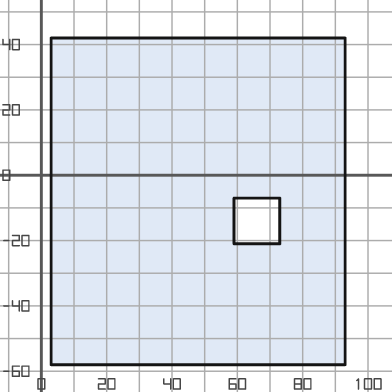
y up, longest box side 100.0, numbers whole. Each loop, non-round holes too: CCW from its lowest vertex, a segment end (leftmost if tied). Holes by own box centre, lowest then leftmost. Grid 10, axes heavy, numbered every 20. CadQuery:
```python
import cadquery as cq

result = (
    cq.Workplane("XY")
    .moveTo(3.0, -58.0)
    .lineTo(93.0, -58.0)
    .lineTo(93.0, 42.0)
    .lineTo(3.0, 42.0)
    .close()
    .moveTo(59.0, -21.0)
    .lineTo(73.0, -21.0)
    .lineTo(73.0, -7.0)
    .lineTo(59.0, -7.0)
    .close()
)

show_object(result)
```